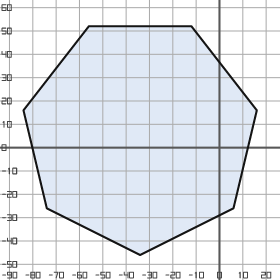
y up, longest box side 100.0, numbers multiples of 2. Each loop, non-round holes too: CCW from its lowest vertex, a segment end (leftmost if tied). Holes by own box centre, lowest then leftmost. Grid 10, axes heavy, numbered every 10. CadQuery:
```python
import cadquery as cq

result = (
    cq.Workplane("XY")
    .moveTo(-34.0, -46.0)
    .lineTo(6.0, -26.0)
    .lineTo(16.0, 16.0)
    .lineTo(-12.0, 52.0)
    .lineTo(-56.0, 52.0)
    .lineTo(-84.0, 16.0)
    .lineTo(-74.0, -26.0)
    .close()
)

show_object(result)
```